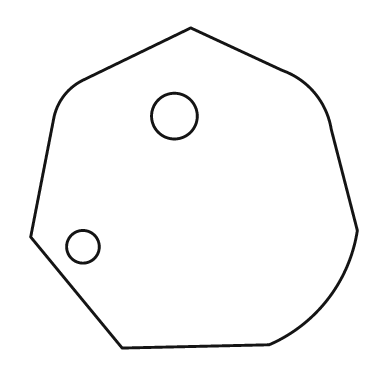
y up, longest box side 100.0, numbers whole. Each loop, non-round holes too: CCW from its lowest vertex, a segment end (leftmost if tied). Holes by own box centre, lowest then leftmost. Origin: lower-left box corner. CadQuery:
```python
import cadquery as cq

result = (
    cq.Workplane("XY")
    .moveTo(28.0, 0.0)
    .lineTo(73.0, 1.0)
    .threePointArc((91.0, 15.0), (100.0, 36.0))
    .lineTo(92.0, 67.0)
    .threePointArc((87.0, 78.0), (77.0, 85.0))
    .lineTo(49.0, 98.0)
    .lineTo(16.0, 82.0)
    .threePointArc((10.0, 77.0), (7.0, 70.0))
    .lineTo(0.0, 34.0)
    .close()
    .moveTo(16.0, 31.0)
    .circle(5.0)
    .moveTo(44.0, 71.0)
    .circle(7.0)
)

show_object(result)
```